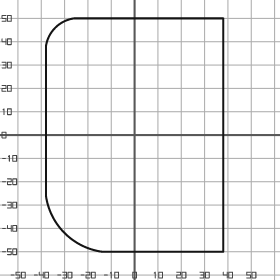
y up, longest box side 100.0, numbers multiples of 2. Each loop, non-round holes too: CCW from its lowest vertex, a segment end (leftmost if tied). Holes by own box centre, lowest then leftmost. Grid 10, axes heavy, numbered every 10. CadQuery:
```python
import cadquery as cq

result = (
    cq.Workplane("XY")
    .moveTo(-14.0, -50.0)
    .lineTo(38.0, -50.0)
    .lineTo(38.0, 50.0)
    .lineTo(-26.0, 50.0)
    .threePointArc((-34.0, 46.0), (-38.0, 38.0))
    .lineTo(-38.0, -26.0)
    .threePointArc((-30.0, -42.0), (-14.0, -50.0))
    .close()
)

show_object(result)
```